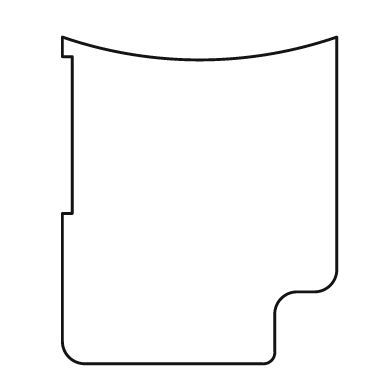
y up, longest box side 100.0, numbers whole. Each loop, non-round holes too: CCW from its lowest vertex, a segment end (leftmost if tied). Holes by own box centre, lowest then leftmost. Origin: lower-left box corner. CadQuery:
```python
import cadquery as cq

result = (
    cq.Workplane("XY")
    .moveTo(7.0, 0.0)
    .lineTo(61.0, 0.0)
    .threePointArc((64.0, 1.0), (65.0, 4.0))
    .lineTo(65.0, 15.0)
    .threePointArc((67.0, 20.0), (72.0, 22.0))
    .lineTo(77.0, 22.0)
    .threePointArc((82.0, 24.0), (84.0, 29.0))
    .lineTo(84.0, 100.0)
    .threePointArc((42.0, 93.0), (0.0, 100.0))
    .lineTo(0.0, 94.0)
    .lineTo(3.0, 94.0)
    .lineTo(3.0, 46.0)
    .lineTo(0.0, 46.0)
    .lineTo(0.0, 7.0)
    .threePointArc((2.0, 2.0), (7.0, 0.0))
    .close()
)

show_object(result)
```